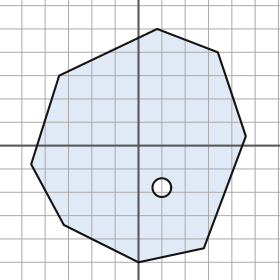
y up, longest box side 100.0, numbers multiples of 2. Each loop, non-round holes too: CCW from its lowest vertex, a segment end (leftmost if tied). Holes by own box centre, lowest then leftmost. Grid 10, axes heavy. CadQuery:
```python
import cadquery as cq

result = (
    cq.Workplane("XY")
    .moveTo(0.0, -50.0)
    .lineTo(28.0, -44.0)
    .lineTo(46.0, 4.0)
    .lineTo(34.0, 40.0)
    .lineTo(8.0, 50.0)
    .lineTo(-34.0, 30.0)
    .lineTo(-46.0, -8.0)
    .lineTo(-32.0, -34.0)
    .close()
    .moveTo(10.0, -18.0)
    .circle(4.0)
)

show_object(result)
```